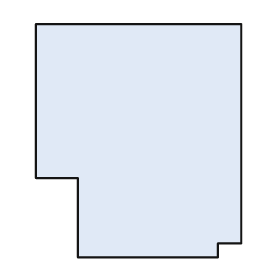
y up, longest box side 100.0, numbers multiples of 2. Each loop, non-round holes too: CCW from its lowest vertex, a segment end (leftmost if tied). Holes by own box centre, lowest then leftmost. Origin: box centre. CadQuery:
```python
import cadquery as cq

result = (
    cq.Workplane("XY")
    .moveTo(-26.0, -50.0)
    .lineTo(34.0, -50.0)
    .lineTo(34.0, -44.0)
    .lineTo(44.0, -44.0)
    .lineTo(44.0, 50.0)
    .lineTo(-44.0, 50.0)
    .lineTo(-44.0, -16.0)
    .lineTo(-26.0, -16.0)
    .close()
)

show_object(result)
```